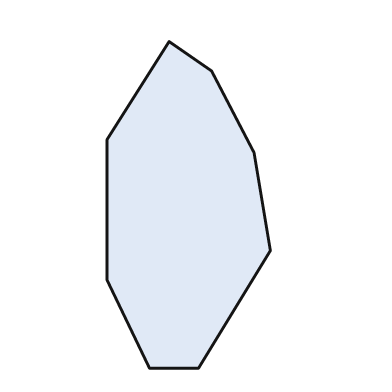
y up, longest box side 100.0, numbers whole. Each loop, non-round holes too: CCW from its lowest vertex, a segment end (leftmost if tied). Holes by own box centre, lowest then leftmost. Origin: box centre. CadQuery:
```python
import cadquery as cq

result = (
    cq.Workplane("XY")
    .moveTo(-12.0, -50.0)
    .lineTo(3.0, -50.0)
    .lineTo(25.0, -14.0)
    .lineTo(20.0, 16.0)
    .lineTo(7.0, 41.0)
    .lineTo(-6.0, 50.0)
    .lineTo(-25.0, 20.0)
    .lineTo(-25.0, -23.0)
    .close()
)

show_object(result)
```